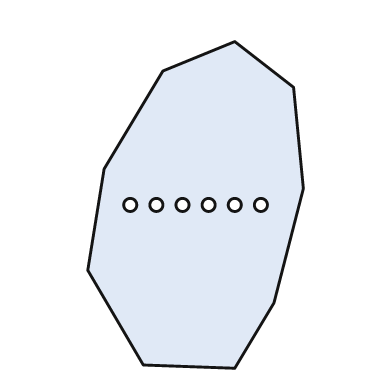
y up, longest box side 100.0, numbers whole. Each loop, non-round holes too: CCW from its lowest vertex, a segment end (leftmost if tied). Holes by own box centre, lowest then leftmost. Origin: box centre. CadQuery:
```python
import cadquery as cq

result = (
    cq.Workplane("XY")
    .moveTo(12.0, -50.0)
    .lineTo(24.0, -30.0)
    .lineTo(33.0, 5.0)
    .lineTo(30.0, 36.0)
    .lineTo(12.0, 50.0)
    .lineTo(-10.0, 41.0)
    .lineTo(-28.0, 11.0)
    .lineTo(-33.0, -20.0)
    .lineTo(-16.0, -49.0)
    .close()
    .moveTo(-20.0, 0.0)
    .circle(2.0)
    .moveTo(-12.0, 0.0)
    .circle(2.0)
    .moveTo(-4.0, 0.0)
    .circle(2.0)
    .moveTo(4.0, 0.0)
    .circle(2.0)
    .moveTo(12.0, 0.0)
    .circle(2.0)
    .moveTo(20.0, 0.0)
    .circle(2.0)
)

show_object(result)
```